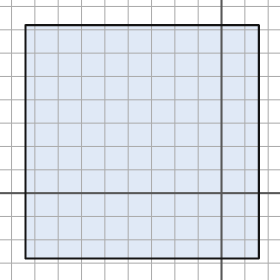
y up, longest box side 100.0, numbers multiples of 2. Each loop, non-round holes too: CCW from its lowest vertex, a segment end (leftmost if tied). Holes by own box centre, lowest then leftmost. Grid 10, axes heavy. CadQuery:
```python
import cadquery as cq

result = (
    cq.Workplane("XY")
    .moveTo(-84.0, -28.0)
    .lineTo(16.0, -28.0)
    .lineTo(16.0, 72.0)
    .lineTo(-84.0, 72.0)
    .close()
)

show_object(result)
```